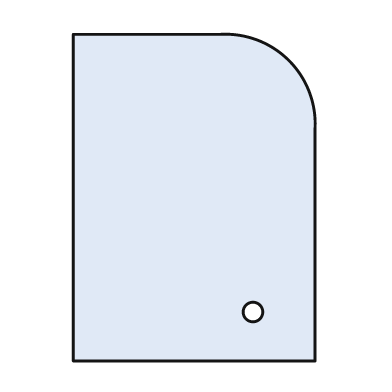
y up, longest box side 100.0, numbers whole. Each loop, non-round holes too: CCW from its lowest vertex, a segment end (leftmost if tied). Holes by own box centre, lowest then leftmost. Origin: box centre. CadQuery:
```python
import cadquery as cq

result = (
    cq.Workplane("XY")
    .moveTo(-37.0, -50.0)
    .lineTo(37.0, -50.0)
    .lineTo(37.0, 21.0)
    .threePointArc((29.0, 42.0), (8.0, 50.0))
    .lineTo(-37.0, 50.0)
    .close()
    .moveTo(18.0, -35.0)
    .circle(3.0)
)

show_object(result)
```